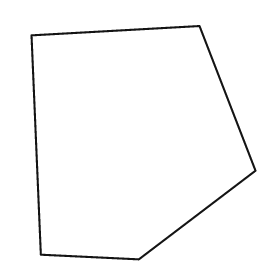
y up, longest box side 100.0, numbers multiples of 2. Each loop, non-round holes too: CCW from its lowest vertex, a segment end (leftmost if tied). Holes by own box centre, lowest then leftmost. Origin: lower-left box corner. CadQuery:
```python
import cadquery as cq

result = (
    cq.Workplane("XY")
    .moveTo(46.0, 0.0)
    .lineTo(96.0, 38.0)
    .lineTo(72.0, 100.0)
    .lineTo(0.0, 96.0)
    .lineTo(4.0, 2.0)
    .close()
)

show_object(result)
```